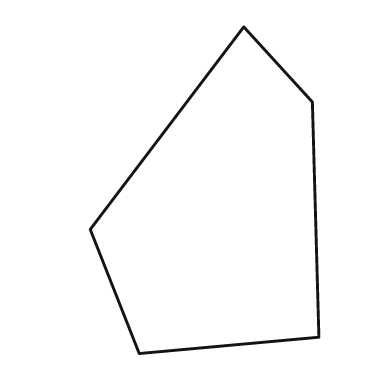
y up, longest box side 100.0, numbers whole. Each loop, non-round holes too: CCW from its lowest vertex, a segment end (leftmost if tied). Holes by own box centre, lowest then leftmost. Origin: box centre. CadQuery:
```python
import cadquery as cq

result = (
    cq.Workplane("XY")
    .moveTo(-20.0, -50.0)
    .lineTo(35.0, -45.0)
    .lineTo(33.0, 27.0)
    .lineTo(12.0, 50.0)
    .lineTo(-35.0, -12.0)
    .close()
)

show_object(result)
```